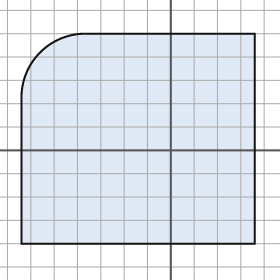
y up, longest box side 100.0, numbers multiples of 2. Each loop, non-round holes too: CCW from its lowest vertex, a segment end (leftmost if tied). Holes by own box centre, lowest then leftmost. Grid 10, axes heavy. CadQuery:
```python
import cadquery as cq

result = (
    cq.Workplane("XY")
    .moveTo(-64.0, -40.0)
    .lineTo(36.0, -40.0)
    .lineTo(36.0, 50.0)
    .lineTo(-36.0, 50.0)
    .threePointArc((-56.0, 42.0), (-64.0, 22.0))
    .close()
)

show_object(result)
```